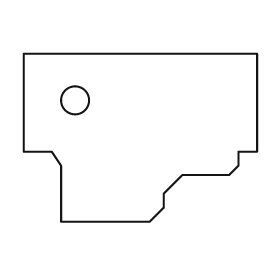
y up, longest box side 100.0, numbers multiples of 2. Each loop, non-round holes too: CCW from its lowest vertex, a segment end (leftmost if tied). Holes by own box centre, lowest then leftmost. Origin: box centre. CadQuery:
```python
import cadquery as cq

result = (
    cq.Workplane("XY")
    .moveTo(-34.0, -36.0)
    .lineTo(4.0, -36.0)
    .lineTo(10.0, -30.0)
    .lineTo(10.0, -24.0)
    .lineTo(18.0, -16.0)
    .lineTo(38.0, -16.0)
    .lineTo(42.0, -12.0)
    .lineTo(42.0, -6.0)
    .lineTo(50.0, -6.0)
    .lineTo(50.0, 36.0)
    .lineTo(-50.0, 36.0)
    .lineTo(-50.0, -6.0)
    .lineTo(-38.0, -6.0)
    .lineTo(-34.0, -12.0)
    .close()
    .moveTo(-28.0, 16.0)
    .circle(6.0)
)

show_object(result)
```